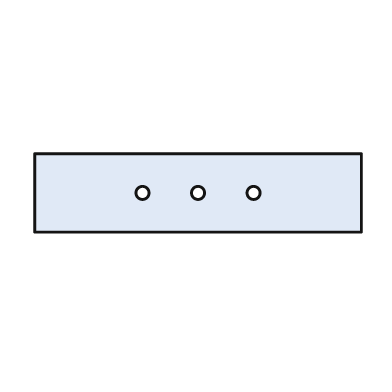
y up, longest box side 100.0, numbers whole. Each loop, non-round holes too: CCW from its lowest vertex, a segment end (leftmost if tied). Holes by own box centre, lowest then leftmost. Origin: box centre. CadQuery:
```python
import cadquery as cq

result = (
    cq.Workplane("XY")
    .moveTo(-50.0, -12.0)
    .lineTo(50.0, -12.0)
    .lineTo(50.0, 12.0)
    .lineTo(-50.0, 12.0)
    .close()
    .moveTo(-17.0, 0.0)
    .circle(2.0)
    .moveTo(0.0, 0.0)
    .circle(2.0)
    .moveTo(17.0, 0.0)
    .circle(2.0)
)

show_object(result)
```